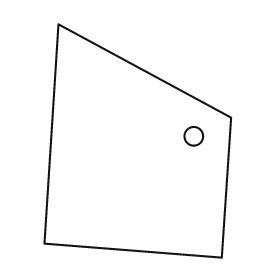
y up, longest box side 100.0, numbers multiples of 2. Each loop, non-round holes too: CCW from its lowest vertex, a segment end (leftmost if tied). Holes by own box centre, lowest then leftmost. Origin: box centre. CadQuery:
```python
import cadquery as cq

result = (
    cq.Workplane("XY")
    .moveTo(36.0, -50.0)
    .lineTo(40.0, 10.0)
    .lineTo(-34.0, 50.0)
    .lineTo(-40.0, -44.0)
    .close()
    .moveTo(24.0, 2.0)
    .circle(4.0)
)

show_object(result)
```